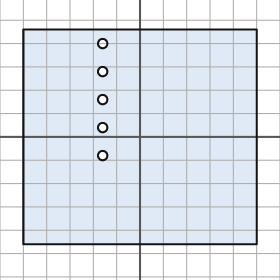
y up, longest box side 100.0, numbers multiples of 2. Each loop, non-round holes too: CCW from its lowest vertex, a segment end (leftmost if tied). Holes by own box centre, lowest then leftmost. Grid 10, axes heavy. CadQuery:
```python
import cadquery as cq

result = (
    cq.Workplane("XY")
    .moveTo(-50.0, -46.0)
    .lineTo(50.0, -46.0)
    .lineTo(50.0, 46.0)
    .lineTo(-50.0, 46.0)
    .close()
    .moveTo(-16.0, -8.0)
    .circle(2.0)
    .moveTo(-16.0, 4.0)
    .circle(2.0)
    .moveTo(-16.0, 16.0)
    .circle(2.0)
    .moveTo(-16.0, 28.0)
    .circle(2.0)
    .moveTo(-16.0, 40.0)
    .circle(2.0)
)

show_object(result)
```